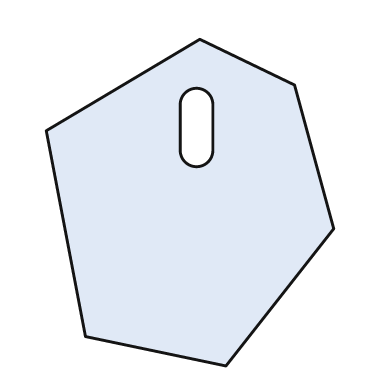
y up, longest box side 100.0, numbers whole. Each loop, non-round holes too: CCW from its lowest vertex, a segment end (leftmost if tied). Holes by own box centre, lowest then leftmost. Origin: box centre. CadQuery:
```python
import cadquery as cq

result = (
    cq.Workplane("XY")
    .moveTo(11.0, -50.0)
    .lineTo(44.0, -8.0)
    .lineTo(32.0, 36.0)
    .lineTo(3.0, 50.0)
    .lineTo(-44.0, 22.0)
    .lineTo(-32.0, -41.0)
    .close()
    .moveTo(-3.0, 16.0)
    .threePointArc((2.0, 11.0), (7.0, 16.0))
    .lineTo(7.0, 30.0)
    .threePointArc((2.0, 35.0), (-3.0, 30.0))
    .close()
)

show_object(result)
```